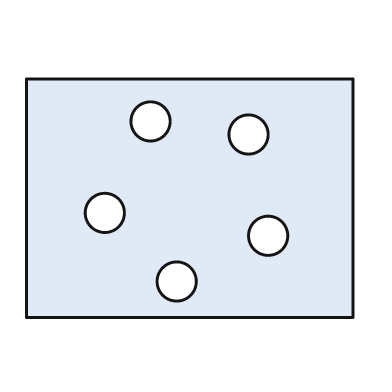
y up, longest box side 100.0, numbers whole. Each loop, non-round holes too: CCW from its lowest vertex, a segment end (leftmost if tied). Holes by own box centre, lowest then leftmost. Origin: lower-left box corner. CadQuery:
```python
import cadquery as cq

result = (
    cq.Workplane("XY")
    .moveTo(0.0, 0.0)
    .lineTo(100.0, 0.0)
    .lineTo(100.0, 73.0)
    .lineTo(0.0, 73.0)
    .close()
    .moveTo(46.0, 11.0)
    .circle(6.0)
    .moveTo(74.0, 25.0)
    .circle(6.0)
    .moveTo(24.0, 32.0)
    .circle(6.0)
    .moveTo(68.0, 56.0)
    .circle(6.0)
    .moveTo(38.0, 60.0)
    .circle(6.0)
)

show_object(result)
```